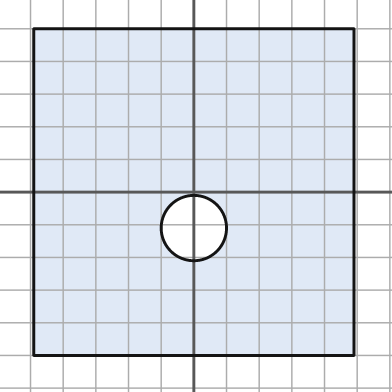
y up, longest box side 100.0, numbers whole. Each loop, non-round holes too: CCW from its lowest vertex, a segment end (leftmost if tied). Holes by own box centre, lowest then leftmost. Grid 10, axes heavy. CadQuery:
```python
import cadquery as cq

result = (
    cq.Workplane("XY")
    .moveTo(-49.0, -50.0)
    .lineTo(49.0, -50.0)
    .lineTo(49.0, 50.0)
    .lineTo(-49.0, 50.0)
    .close()
    .moveTo(0.0, -11.0)
    .circle(10.0)
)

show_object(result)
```